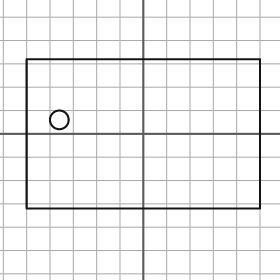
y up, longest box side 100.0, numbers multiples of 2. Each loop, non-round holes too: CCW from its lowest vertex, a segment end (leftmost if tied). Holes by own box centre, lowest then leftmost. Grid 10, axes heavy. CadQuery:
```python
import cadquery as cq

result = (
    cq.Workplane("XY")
    .moveTo(-50.0, -32.0)
    .lineTo(50.0, -32.0)
    .lineTo(50.0, 32.0)
    .lineTo(-50.0, 32.0)
    .close()
    .moveTo(-36.0, 6.0)
    .circle(4.0)
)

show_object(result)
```